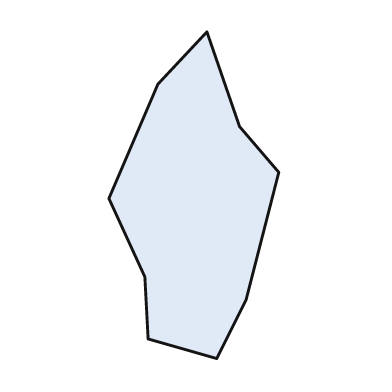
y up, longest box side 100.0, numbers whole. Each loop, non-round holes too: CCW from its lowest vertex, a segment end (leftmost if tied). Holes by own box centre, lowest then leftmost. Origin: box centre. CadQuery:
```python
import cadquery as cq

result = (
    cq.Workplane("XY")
    .moveTo(7.0, -50.0)
    .lineTo(16.0, -32.0)
    .lineTo(26.0, 7.0)
    .lineTo(14.0, 21.0)
    .lineTo(4.0, 50.0)
    .lineTo(-11.0, 34.0)
    .lineTo(-26.0, -1.0)
    .lineTo(-15.0, -25.0)
    .lineTo(-14.0, -44.0)
    .close()
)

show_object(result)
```